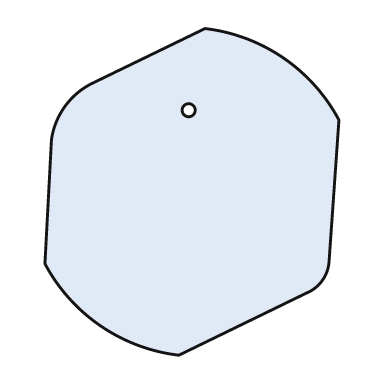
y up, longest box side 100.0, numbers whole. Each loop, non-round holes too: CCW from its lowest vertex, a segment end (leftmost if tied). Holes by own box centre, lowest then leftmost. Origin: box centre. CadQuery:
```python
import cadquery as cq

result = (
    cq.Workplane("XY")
    .moveTo(-4.0, -50.0)
    .lineTo(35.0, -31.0)
    .threePointArc((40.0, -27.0), (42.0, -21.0))
    .lineTo(45.0, 22.0)
    .threePointArc((28.0, 41.0), (4.0, 50.0))
    .lineTo(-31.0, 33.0)
    .threePointArc((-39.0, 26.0), (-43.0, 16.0))
    .lineTo(-45.0, -22.0)
    .threePointArc((-28.0, -41.0), (-4.0, -50.0))
    .close()
    .moveTo(-1.0, 25.0)
    .circle(2.0)
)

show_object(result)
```